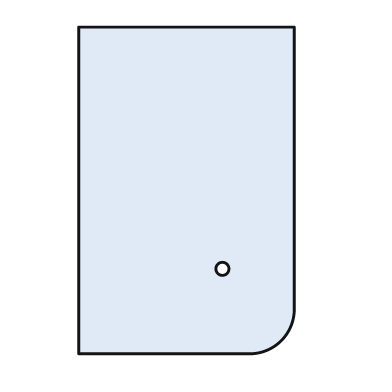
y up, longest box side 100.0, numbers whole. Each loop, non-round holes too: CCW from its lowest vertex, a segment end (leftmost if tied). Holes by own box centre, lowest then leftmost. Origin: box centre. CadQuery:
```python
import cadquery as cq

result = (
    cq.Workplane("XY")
    .moveTo(-33.0, -50.0)
    .lineTo(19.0, -50.0)
    .threePointArc((29.0, -46.0), (33.0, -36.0))
    .lineTo(33.0, 50.0)
    .lineTo(-33.0, 50.0)
    .close()
    .moveTo(11.0, -24.0)
    .circle(2.0)
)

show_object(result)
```